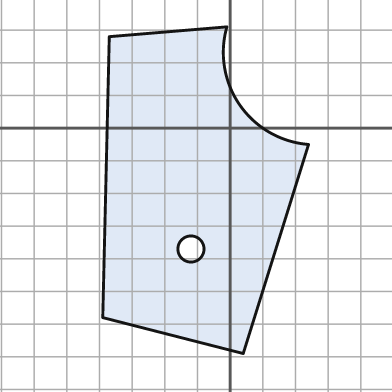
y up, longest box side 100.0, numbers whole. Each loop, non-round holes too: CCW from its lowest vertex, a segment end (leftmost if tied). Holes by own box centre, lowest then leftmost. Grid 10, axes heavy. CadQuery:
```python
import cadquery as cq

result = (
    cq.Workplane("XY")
    .moveTo(4.0, -69.0)
    .lineTo(24.0, -5.0)
    .threePointArc((3.0, 7.0), (-1.0, 31.0))
    .lineTo(-37.0, 28.0)
    .lineTo(-39.0, -58.0)
    .close()
    .moveTo(-12.0, -37.0)
    .circle(4.0)
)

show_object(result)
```